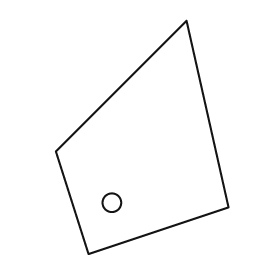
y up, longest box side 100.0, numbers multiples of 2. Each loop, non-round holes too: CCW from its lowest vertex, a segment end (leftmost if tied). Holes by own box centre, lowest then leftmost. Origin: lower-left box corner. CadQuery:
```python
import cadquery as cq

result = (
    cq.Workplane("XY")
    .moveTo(14.0, 0.0)
    .lineTo(74.0, 20.0)
    .lineTo(56.0, 100.0)
    .lineTo(0.0, 44.0)
    .close()
    .moveTo(24.0, 22.0)
    .circle(4.0)
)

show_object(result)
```